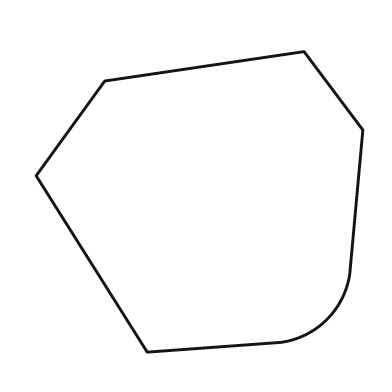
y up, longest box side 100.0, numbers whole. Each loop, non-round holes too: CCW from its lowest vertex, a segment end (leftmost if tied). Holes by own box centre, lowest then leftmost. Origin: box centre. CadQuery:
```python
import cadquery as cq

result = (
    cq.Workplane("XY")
    .moveTo(-16.0, -46.0)
    .lineTo(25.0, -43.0)
    .threePointArc((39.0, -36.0), (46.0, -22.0))
    .lineTo(50.0, 22.0)
    .lineTo(32.0, 46.0)
    .lineTo(-29.0, 37.0)
    .lineTo(-50.0, 8.0)
    .close()
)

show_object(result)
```